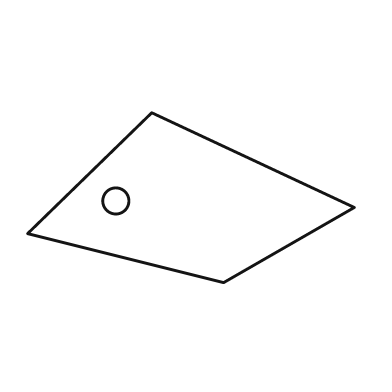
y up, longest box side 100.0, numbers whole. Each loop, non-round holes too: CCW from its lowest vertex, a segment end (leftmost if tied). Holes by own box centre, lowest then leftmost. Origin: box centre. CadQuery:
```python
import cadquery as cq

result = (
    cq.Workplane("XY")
    .moveTo(10.0, -26.0)
    .lineTo(50.0, -3.0)
    .lineTo(-12.0, 26.0)
    .lineTo(-50.0, -11.0)
    .close()
    .moveTo(-23.0, -1.0)
    .circle(4.0)
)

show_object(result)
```